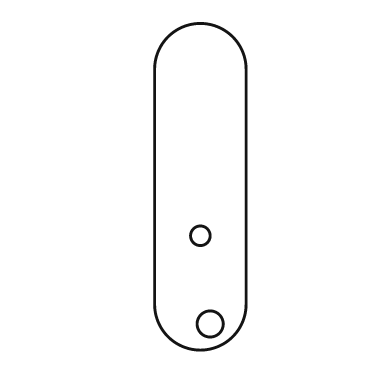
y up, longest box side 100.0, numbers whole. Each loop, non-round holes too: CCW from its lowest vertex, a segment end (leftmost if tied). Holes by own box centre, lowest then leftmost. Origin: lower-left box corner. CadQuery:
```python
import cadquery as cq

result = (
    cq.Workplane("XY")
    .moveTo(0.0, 14.0)
    .threePointArc((14.0, 0.0), (28.0, 14.0))
    .lineTo(28.0, 86.0)
    .threePointArc((14.0, 100.0), (0.0, 86.0))
    .close()
    .moveTo(17.0, 8.0)
    .circle(4.0)
    .moveTo(14.0, 35.0)
    .circle(3.0)
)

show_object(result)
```